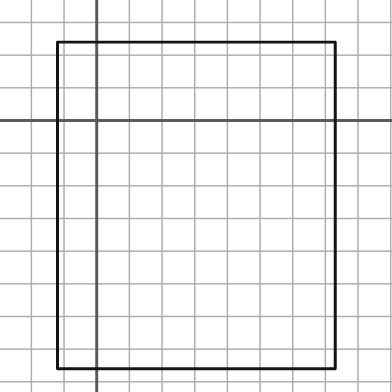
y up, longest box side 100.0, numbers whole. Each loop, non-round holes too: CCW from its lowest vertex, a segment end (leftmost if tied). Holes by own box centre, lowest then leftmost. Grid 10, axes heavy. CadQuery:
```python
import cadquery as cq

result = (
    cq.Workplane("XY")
    .moveTo(-12.0, -76.0)
    .lineTo(73.0, -76.0)
    .lineTo(73.0, 24.0)
    .lineTo(-12.0, 24.0)
    .close()
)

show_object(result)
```